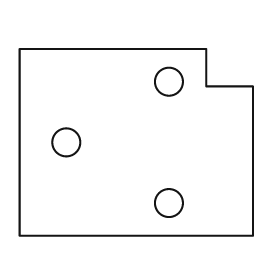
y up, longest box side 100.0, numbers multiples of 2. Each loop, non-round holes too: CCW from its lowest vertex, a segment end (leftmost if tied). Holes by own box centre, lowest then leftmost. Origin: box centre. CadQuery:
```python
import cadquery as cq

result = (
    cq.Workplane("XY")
    .moveTo(-50.0, -40.0)
    .lineTo(50.0, -40.0)
    .lineTo(50.0, 24.0)
    .lineTo(30.0, 24.0)
    .lineTo(30.0, 40.0)
    .lineTo(-50.0, 40.0)
    .close()
    .moveTo(14.0, -26.0)
    .circle(6.0)
    .moveTo(-30.0, 0.0)
    .circle(6.0)
    .moveTo(14.0, 26.0)
    .circle(6.0)
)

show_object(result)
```